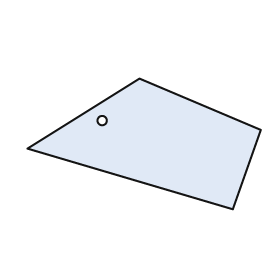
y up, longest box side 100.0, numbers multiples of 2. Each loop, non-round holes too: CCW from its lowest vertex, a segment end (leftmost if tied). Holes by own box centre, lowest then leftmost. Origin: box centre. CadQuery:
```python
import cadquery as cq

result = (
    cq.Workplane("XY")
    .moveTo(38.0, -28.0)
    .lineTo(50.0, 6.0)
    .lineTo(-2.0, 28.0)
    .lineTo(-50.0, -2.0)
    .close()
    .moveTo(-18.0, 10.0)
    .circle(2.0)
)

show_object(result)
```